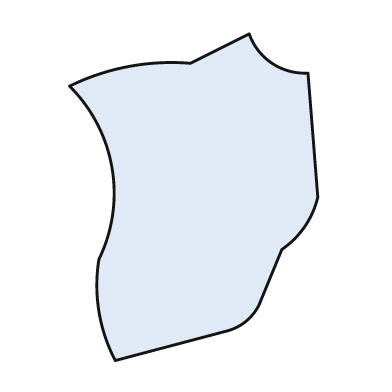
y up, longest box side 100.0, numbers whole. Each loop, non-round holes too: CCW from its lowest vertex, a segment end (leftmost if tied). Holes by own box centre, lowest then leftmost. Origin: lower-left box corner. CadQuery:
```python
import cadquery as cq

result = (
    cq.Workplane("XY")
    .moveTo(14.0, 0.0)
    .lineTo(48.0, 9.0)
    .threePointArc((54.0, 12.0), (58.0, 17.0))
    .lineTo(65.0, 34.0)
    .threePointArc((72.0, 41.0), (76.0, 50.0))
    .lineTo(73.0, 88.0)
    .threePointArc((62.0, 91.0), (55.0, 100.0))
    .lineTo(37.0, 91.0)
    .threePointArc((18.0, 90.0), (0.0, 84.0))
    .threePointArc((13.0, 59.0), (9.0, 31.0))
    .threePointArc((9.0, 15.0), (14.0, 0.0))
    .close()
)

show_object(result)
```